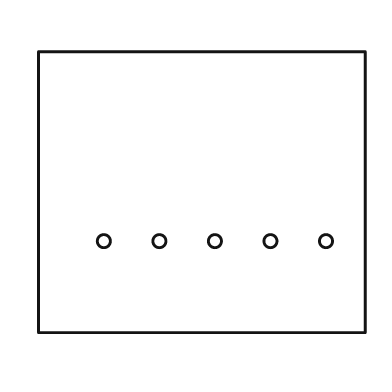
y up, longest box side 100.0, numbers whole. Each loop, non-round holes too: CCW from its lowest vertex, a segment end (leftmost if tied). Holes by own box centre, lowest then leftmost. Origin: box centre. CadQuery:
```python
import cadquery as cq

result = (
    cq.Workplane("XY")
    .moveTo(-50.0, -43.0)
    .lineTo(50.0, -43.0)
    .lineTo(50.0, 43.0)
    .lineTo(-50.0, 43.0)
    .close()
    .moveTo(-30.0, -15.0)
    .circle(2.0)
    .moveTo(-13.0, -15.0)
    .circle(2.0)
    .moveTo(4.0, -15.0)
    .circle(2.0)
    .moveTo(21.0, -15.0)
    .circle(2.0)
    .moveTo(38.0, -15.0)
    .circle(2.0)
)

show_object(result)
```